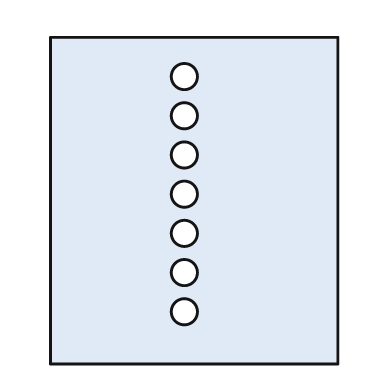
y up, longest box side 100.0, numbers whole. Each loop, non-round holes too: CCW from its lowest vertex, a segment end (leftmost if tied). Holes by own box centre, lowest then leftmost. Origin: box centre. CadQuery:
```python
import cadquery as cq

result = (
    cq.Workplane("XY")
    .moveTo(-44.0, -50.0)
    .lineTo(44.0, -50.0)
    .lineTo(44.0, 50.0)
    .lineTo(-44.0, 50.0)
    .close()
    .moveTo(-3.0, -34.0)
    .circle(4.0)
    .moveTo(-3.0, -22.0)
    .circle(4.0)
    .moveTo(-3.0, -10.0)
    .circle(4.0)
    .moveTo(-3.0, 2.0)
    .circle(4.0)
    .moveTo(-3.0, 14.0)
    .circle(4.0)
    .moveTo(-3.0, 26.0)
    .circle(4.0)
    .moveTo(-3.0, 38.0)
    .circle(4.0)
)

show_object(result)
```